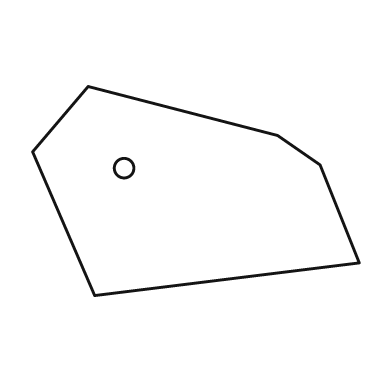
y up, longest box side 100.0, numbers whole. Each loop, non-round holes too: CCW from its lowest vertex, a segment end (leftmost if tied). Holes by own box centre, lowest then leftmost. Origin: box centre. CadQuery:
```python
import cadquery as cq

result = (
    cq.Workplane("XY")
    .moveTo(-31.0, -32.0)
    .lineTo(50.0, -22.0)
    .lineTo(38.0, 8.0)
    .lineTo(25.0, 17.0)
    .lineTo(-33.0, 32.0)
    .lineTo(-50.0, 12.0)
    .close()
    .moveTo(-22.0, 7.0)
    .circle(3.0)
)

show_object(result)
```